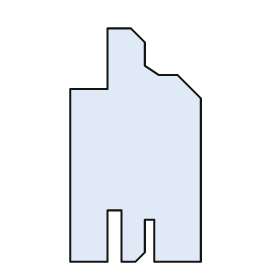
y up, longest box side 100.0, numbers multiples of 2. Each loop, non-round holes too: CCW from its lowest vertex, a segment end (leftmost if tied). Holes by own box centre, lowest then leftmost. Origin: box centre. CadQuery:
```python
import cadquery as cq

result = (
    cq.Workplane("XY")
    .moveTo(-28.0, -50.0)
    .lineTo(-12.0, -50.0)
    .lineTo(-12.0, -28.0)
    .lineTo(-6.0, -28.0)
    .lineTo(-6.0, -50.0)
    .lineTo(0.0, -50.0)
    .lineTo(4.0, -46.0)
    .lineTo(4.0, -32.0)
    .lineTo(8.0, -32.0)
    .lineTo(8.0, -50.0)
    .lineTo(28.0, -50.0)
    .lineTo(28.0, 20.0)
    .lineTo(18.0, 30.0)
    .lineTo(10.0, 30.0)
    .lineTo(4.0, 34.0)
    .lineTo(4.0, 44.0)
    .lineTo(-2.0, 50.0)
    .lineTo(-12.0, 50.0)
    .lineTo(-12.0, 24.0)
    .lineTo(-28.0, 24.0)
    .close()
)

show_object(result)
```